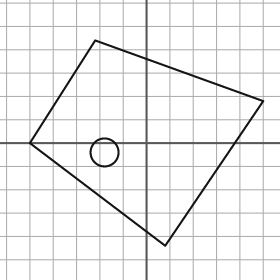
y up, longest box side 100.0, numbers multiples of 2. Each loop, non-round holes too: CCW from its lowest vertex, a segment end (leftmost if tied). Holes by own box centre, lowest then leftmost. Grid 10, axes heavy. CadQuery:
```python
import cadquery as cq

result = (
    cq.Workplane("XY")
    .moveTo(8.0, -44.0)
    .lineTo(50.0, 18.0)
    .lineTo(-22.0, 44.0)
    .lineTo(-50.0, 0.0)
    .close()
    .moveTo(-18.0, -4.0)
    .circle(6.0)
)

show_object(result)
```